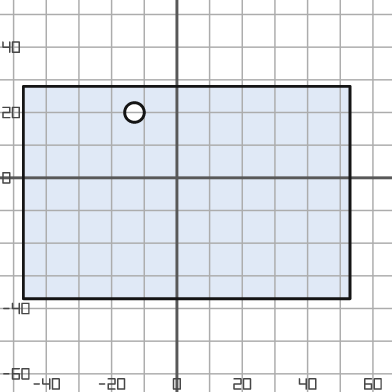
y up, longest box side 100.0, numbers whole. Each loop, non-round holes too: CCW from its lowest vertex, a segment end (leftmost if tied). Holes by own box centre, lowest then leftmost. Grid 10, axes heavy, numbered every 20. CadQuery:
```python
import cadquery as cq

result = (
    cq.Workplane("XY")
    .moveTo(-47.0, -37.0)
    .lineTo(53.0, -37.0)
    .lineTo(53.0, 28.0)
    .lineTo(-47.0, 28.0)
    .close()
    .moveTo(-13.0, 20.0)
    .circle(3.0)
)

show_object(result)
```